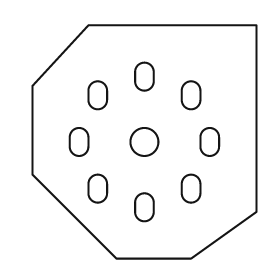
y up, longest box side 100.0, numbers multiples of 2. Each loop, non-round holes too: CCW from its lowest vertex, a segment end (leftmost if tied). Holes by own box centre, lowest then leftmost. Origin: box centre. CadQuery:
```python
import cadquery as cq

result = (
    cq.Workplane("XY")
    .moveTo(-12.0, -50.0)
    .lineTo(20.0, -50.0)
    .lineTo(48.0, -30.0)
    .lineTo(48.0, 50.0)
    .lineTo(-24.0, 50.0)
    .lineTo(-48.0, 24.0)
    .lineTo(-48.0, -14.0)
    .close()
    .moveTo(-4.0, -30.0)
    .threePointArc((0.0, -34.0), (4.0, -30.0))
    .lineTo(4.0, -26.0)
    .threePointArc((0.0, -22.0), (-4.0, -26.0))
    .close()
    .moveTo(-24.0, -22.0)
    .threePointArc((-20.0, -26.0), (-16.0, -22.0))
    .lineTo(-16.0, -18.0)
    .threePointArc((-20.0, -14.0), (-24.0, -18.0))
    .close()
    .moveTo(16.0, -22.0)
    .threePointArc((20.0, -26.0), (24.0, -22.0))
    .lineTo(24.0, -18.0)
    .threePointArc((20.0, -14.0), (16.0, -18.0))
    .close()
    .moveTo(-32.0, -2.0)
    .threePointArc((-28.0, -6.0), (-24.0, -2.0))
    .lineTo(-24.0, 2.0)
    .threePointArc((-28.0, 6.0), (-32.0, 2.0))
    .close()
    .moveTo(0.0, 0.0)
    .circle(6.0)
    .moveTo(24.0, -2.0)
    .threePointArc((28.0, -6.0), (32.0, -2.0))
    .lineTo(32.0, 2.0)
    .threePointArc((28.0, 6.0), (24.0, 2.0))
    .close()
    .moveTo(-24.0, 18.0)
    .threePointArc((-20.0, 14.0), (-16.0, 18.0))
    .lineTo(-16.0, 22.0)
    .threePointArc((-20.0, 26.0), (-24.0, 22.0))
    .close()
    .moveTo(16.0, 18.0)
    .threePointArc((20.0, 14.0), (24.0, 18.0))
    .lineTo(24.0, 22.0)
    .threePointArc((20.0, 26.0), (16.0, 22.0))
    .close()
    .moveTo(-4.0, 26.0)
    .threePointArc((0.0, 22.0), (4.0, 26.0))
    .lineTo(4.0, 30.0)
    .threePointArc((0.0, 34.0), (-4.0, 30.0))
    .close()
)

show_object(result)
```